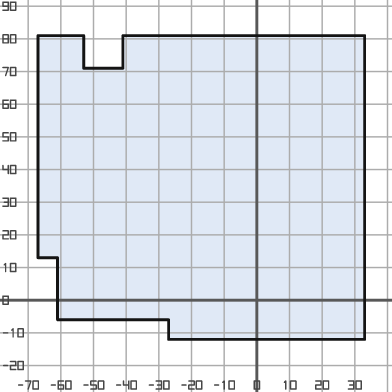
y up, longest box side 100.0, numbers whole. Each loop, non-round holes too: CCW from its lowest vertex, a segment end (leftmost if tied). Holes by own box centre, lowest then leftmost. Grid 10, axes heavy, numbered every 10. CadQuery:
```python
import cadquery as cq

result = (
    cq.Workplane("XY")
    .moveTo(-27.0, -12.0)
    .lineTo(33.0, -12.0)
    .lineTo(33.0, 81.0)
    .lineTo(-41.0, 81.0)
    .lineTo(-41.0, 71.0)
    .lineTo(-53.0, 71.0)
    .lineTo(-53.0, 81.0)
    .lineTo(-67.0, 81.0)
    .lineTo(-67.0, 13.0)
    .lineTo(-61.0, 13.0)
    .lineTo(-61.0, -6.0)
    .lineTo(-27.0, -6.0)
    .close()
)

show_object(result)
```